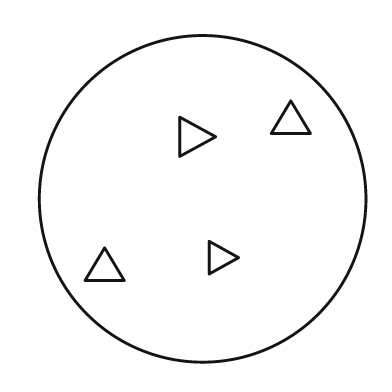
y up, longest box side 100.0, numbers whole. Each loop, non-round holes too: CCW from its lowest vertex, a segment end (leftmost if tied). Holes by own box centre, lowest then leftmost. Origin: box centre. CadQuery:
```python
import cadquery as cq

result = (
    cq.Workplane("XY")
    .moveTo(0.0, 0.0)
    .circle(50.0)
    .moveTo(-36.0, -25.0)
    .lineTo(-24.0, -25.0)
    .lineTo(-30.0, -15.0)
    .close()
    .moveTo(2.0, -23.0)
    .lineTo(11.0, -18.0)
    .lineTo(2.0, -13.0)
    .close()
    .moveTo(-7.0, 13.0)
    .lineTo(4.0, 19.0)
    .lineTo(-7.0, 25.0)
    .close()
    .moveTo(21.0, 20.0)
    .lineTo(33.0, 20.0)
    .lineTo(27.0, 30.0)
    .close()
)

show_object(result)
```